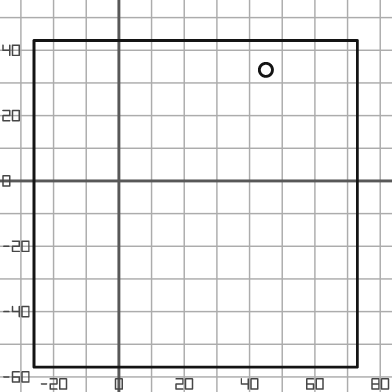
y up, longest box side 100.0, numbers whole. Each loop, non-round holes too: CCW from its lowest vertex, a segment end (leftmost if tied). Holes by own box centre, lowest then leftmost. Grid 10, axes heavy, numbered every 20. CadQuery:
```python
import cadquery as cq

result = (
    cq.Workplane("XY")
    .moveTo(-26.0, -57.0)
    .lineTo(73.0, -57.0)
    .lineTo(73.0, 43.0)
    .lineTo(-26.0, 43.0)
    .close()
    .moveTo(45.0, 34.0)
    .circle(2.0)
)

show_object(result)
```